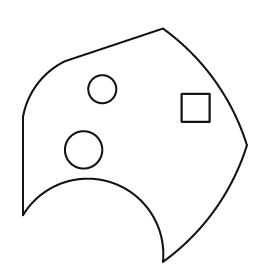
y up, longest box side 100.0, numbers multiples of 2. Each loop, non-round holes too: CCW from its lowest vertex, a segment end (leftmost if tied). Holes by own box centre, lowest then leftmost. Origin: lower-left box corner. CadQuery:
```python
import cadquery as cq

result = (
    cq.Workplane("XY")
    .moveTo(60.0, 0.0)
    .threePointArc((82.0, 22.0), (96.0, 50.0))
    .threePointArc((82.0, 78.0), (60.0, 100.0))
    .lineTo(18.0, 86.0)
    .threePointArc((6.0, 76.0), (0.0, 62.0))
    .lineTo(0.0, 20.0)
    .threePointArc((38.0, 34.0), (60.0, 0.0))
    .close()
    .moveTo(26.0, 48.0)
    .circle(8.0)
    .moveTo(68.0, 60.0)
    .lineTo(80.0, 60.0)
    .lineTo(80.0, 72.0)
    .lineTo(68.0, 72.0)
    .close()
    .moveTo(34.0, 74.0)
    .circle(6.0)
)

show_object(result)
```